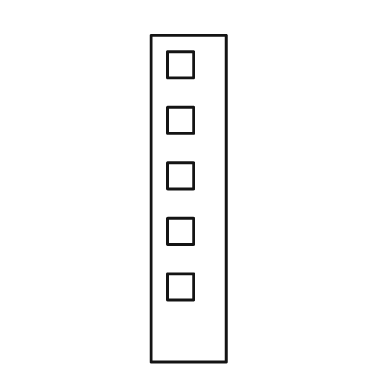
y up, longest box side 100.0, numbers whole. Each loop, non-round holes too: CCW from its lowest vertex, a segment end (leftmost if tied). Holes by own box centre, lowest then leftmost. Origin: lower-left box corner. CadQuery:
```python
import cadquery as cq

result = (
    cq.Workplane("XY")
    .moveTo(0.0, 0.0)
    .lineTo(23.0, 0.0)
    .lineTo(23.0, 100.0)
    .lineTo(0.0, 100.0)
    .close()
    .moveTo(5.0, 19.0)
    .lineTo(13.0, 19.0)
    .lineTo(13.0, 27.0)
    .lineTo(5.0, 27.0)
    .close()
    .moveTo(5.0, 36.0)
    .lineTo(13.0, 36.0)
    .lineTo(13.0, 44.0)
    .lineTo(5.0, 44.0)
    .close()
    .moveTo(5.0, 53.0)
    .lineTo(13.0, 53.0)
    .lineTo(13.0, 61.0)
    .lineTo(5.0, 61.0)
    .close()
    .moveTo(5.0, 70.0)
    .lineTo(13.0, 70.0)
    .lineTo(13.0, 78.0)
    .lineTo(5.0, 78.0)
    .close()
    .moveTo(5.0, 87.0)
    .lineTo(13.0, 87.0)
    .lineTo(13.0, 95.0)
    .lineTo(5.0, 95.0)
    .close()
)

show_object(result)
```